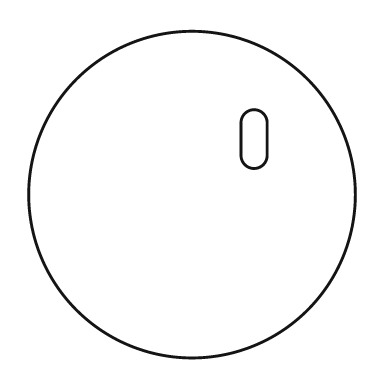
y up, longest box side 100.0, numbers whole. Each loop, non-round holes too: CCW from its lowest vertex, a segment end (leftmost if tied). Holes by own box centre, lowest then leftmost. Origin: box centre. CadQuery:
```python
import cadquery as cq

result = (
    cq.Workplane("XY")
    .moveTo(0.0, 0.0)
    .circle(50.0)
    .moveTo(15.0, 12.0)
    .threePointArc((19.0, 8.0), (23.0, 12.0))
    .lineTo(23.0, 22.0)
    .threePointArc((19.0, 26.0), (15.0, 22.0))
    .close()
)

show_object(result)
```